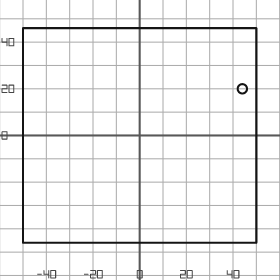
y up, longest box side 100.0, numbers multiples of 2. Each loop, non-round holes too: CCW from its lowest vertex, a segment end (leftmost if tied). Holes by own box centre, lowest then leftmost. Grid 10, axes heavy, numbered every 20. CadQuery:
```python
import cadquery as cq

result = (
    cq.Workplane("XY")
    .moveTo(-50.0, -46.0)
    .lineTo(50.0, -46.0)
    .lineTo(50.0, 46.0)
    .lineTo(-50.0, 46.0)
    .close()
    .moveTo(44.0, 20.0)
    .circle(2.0)
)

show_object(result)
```